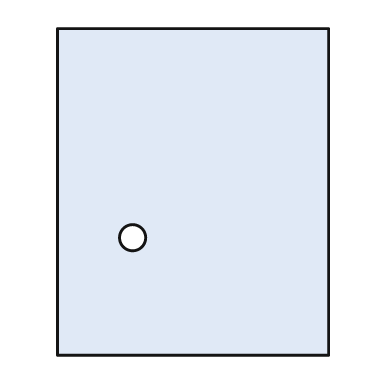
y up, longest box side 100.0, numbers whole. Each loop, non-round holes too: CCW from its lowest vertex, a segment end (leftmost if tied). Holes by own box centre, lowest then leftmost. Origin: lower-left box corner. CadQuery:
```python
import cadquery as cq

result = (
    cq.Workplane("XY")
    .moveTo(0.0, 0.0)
    .lineTo(83.0, 0.0)
    .lineTo(83.0, 100.0)
    .lineTo(0.0, 100.0)
    .close()
    .moveTo(23.0, 36.0)
    .circle(4.0)
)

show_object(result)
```